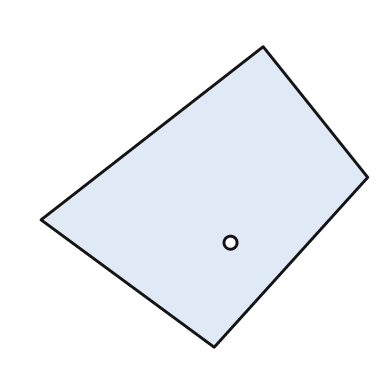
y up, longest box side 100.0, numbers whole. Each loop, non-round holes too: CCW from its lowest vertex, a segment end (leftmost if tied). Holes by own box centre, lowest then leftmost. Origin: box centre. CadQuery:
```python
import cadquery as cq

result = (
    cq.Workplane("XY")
    .moveTo(3.0, -46.0)
    .lineTo(50.0, 6.0)
    .lineTo(18.0, 46.0)
    .lineTo(-50.0, -7.0)
    .close()
    .moveTo(8.0, -14.0)
    .circle(2.0)
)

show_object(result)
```